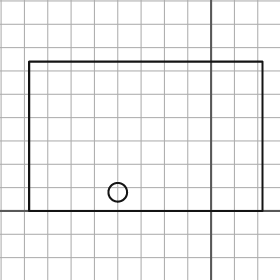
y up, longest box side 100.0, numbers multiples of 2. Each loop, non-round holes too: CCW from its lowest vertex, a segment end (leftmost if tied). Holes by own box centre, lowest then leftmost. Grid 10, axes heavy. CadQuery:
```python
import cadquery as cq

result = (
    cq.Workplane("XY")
    .moveTo(-78.0, 0.0)
    .lineTo(22.0, 0.0)
    .lineTo(22.0, 64.0)
    .lineTo(-78.0, 64.0)
    .close()
    .moveTo(-40.0, 8.0)
    .circle(4.0)
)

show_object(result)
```